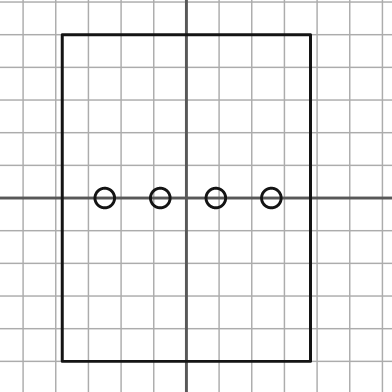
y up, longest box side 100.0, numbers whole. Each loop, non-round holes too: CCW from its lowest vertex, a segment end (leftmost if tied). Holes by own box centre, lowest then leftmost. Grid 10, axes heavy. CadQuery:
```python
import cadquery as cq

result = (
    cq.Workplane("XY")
    .moveTo(-38.0, -50.0)
    .lineTo(38.0, -50.0)
    .lineTo(38.0, 50.0)
    .lineTo(-38.0, 50.0)
    .close()
    .moveTo(-25.0, 0.0)
    .circle(3.0)
    .moveTo(-8.0, 0.0)
    .circle(3.0)
    .moveTo(9.0, 0.0)
    .circle(3.0)
    .moveTo(26.0, 0.0)
    .circle(3.0)
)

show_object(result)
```